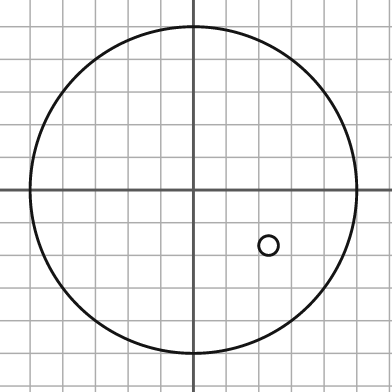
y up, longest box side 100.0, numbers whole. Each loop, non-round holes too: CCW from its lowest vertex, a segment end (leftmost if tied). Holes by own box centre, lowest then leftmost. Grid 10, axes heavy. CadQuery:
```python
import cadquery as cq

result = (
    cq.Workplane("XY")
    .moveTo(0.0, 0.0)
    .circle(50.0)
    .moveTo(23.0, -17.0)
    .circle(3.0)
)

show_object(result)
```